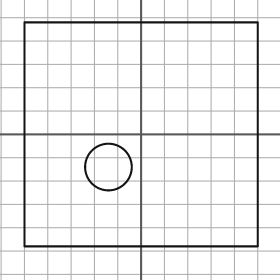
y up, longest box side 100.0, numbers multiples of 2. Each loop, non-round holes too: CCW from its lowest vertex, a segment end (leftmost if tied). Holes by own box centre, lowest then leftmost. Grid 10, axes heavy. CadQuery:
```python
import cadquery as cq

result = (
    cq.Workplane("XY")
    .moveTo(-50.0, -48.0)
    .lineTo(50.0, -48.0)
    .lineTo(50.0, 48.0)
    .lineTo(-50.0, 48.0)
    .close()
    .moveTo(-14.0, -14.0)
    .circle(10.0)
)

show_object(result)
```